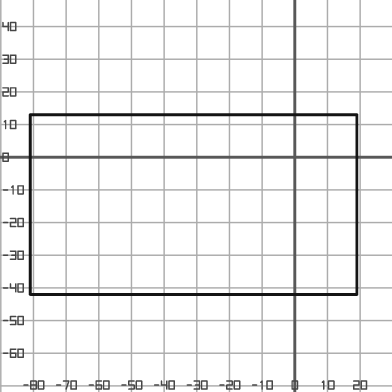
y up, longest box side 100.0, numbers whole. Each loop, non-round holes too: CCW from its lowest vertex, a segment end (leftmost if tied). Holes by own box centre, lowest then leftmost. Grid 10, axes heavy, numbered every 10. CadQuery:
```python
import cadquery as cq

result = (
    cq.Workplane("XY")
    .moveTo(-81.0, -42.0)
    .lineTo(19.0, -42.0)
    .lineTo(19.0, 13.0)
    .lineTo(-81.0, 13.0)
    .close()
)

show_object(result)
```